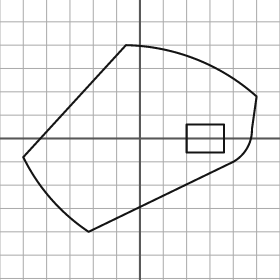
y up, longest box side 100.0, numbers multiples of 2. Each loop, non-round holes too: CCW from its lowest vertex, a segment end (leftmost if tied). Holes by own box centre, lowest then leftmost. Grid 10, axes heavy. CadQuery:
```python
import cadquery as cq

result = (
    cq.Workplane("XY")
    .moveTo(-22.0, -40.0)
    .lineTo(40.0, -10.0)
    .threePointArc((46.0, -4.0), (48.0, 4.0))
    .lineTo(50.0, 18.0)
    .threePointArc((24.0, 34.0), (-6.0, 40.0))
    .lineTo(-50.0, -8.0)
    .threePointArc((-38.0, -26.0), (-22.0, -40.0))
    .close()
    .moveTo(20.0, -6.0)
    .lineTo(36.0, -6.0)
    .lineTo(36.0, 6.0)
    .lineTo(20.0, 6.0)
    .close()
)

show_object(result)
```